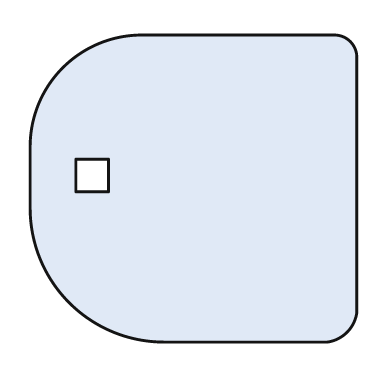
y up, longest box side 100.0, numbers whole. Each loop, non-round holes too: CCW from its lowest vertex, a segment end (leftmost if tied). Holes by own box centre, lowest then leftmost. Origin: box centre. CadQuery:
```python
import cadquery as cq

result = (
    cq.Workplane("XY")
    .moveTo(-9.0, -47.0)
    .lineTo(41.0, -47.0)
    .threePointArc((47.0, -44.0), (50.0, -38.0))
    .lineTo(50.0, 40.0)
    .threePointArc((48.0, 45.0), (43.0, 47.0))
    .lineTo(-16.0, 47.0)
    .threePointArc((-40.0, 37.0), (-50.0, 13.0))
    .lineTo(-50.0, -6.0)
    .threePointArc((-38.0, -35.0), (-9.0, -47.0))
    .close()
    .moveTo(-36.0, -1.0)
    .lineTo(-26.0, -1.0)
    .lineTo(-26.0, 9.0)
    .lineTo(-36.0, 9.0)
    .close()
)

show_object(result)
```